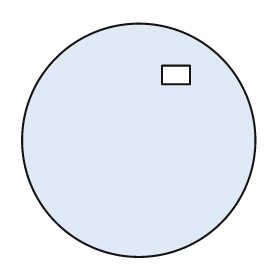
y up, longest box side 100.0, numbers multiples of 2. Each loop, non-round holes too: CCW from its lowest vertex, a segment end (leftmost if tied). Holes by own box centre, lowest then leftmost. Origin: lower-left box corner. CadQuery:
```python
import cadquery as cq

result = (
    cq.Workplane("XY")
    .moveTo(50.0, 50.0)
    .circle(50.0)
    .moveTo(60.0, 74.0)
    .lineTo(72.0, 74.0)
    .lineTo(72.0, 82.0)
    .lineTo(60.0, 82.0)
    .close()
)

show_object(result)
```